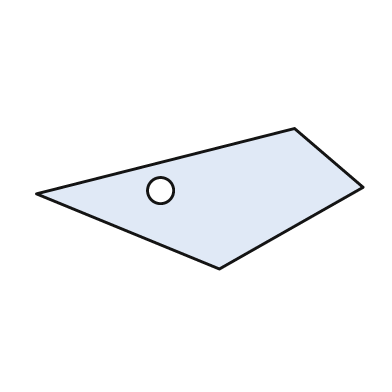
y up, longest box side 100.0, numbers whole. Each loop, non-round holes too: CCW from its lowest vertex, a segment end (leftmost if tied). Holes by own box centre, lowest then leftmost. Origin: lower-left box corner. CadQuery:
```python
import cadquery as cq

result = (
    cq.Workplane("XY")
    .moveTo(56.0, 0.0)
    .lineTo(100.0, 25.0)
    .lineTo(79.0, 43.0)
    .lineTo(0.0, 23.0)
    .close()
    .moveTo(38.0, 24.0)
    .circle(4.0)
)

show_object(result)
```